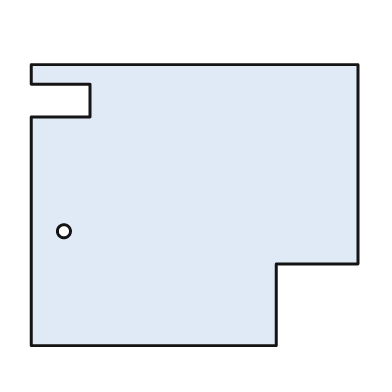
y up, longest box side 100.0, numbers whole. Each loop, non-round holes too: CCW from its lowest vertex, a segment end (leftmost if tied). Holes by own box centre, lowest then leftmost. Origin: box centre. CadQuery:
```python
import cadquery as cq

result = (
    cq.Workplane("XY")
    .moveTo(-50.0, -43.0)
    .lineTo(25.0, -43.0)
    .lineTo(25.0, -18.0)
    .lineTo(50.0, -18.0)
    .lineTo(50.0, 43.0)
    .lineTo(-50.0, 43.0)
    .lineTo(-50.0, 37.0)
    .lineTo(-32.0, 37.0)
    .lineTo(-32.0, 27.0)
    .lineTo(-50.0, 27.0)
    .close()
    .moveTo(-40.0, -8.0)
    .circle(2.0)
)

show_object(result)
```